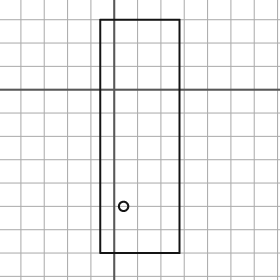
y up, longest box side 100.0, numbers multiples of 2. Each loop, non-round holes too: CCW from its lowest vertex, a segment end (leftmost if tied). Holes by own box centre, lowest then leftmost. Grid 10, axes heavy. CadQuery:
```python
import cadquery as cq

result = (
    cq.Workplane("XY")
    .moveTo(-6.0, -70.0)
    .lineTo(28.0, -70.0)
    .lineTo(28.0, 30.0)
    .lineTo(-6.0, 30.0)
    .close()
    .moveTo(4.0, -50.0)
    .circle(2.0)
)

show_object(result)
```